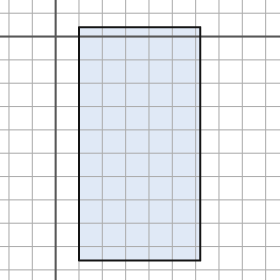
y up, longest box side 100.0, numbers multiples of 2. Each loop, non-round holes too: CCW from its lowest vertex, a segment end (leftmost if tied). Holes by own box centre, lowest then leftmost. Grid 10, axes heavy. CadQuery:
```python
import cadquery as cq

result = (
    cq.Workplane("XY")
    .moveTo(10.0, -96.0)
    .lineTo(62.0, -96.0)
    .lineTo(62.0, 4.0)
    .lineTo(10.0, 4.0)
    .close()
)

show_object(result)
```